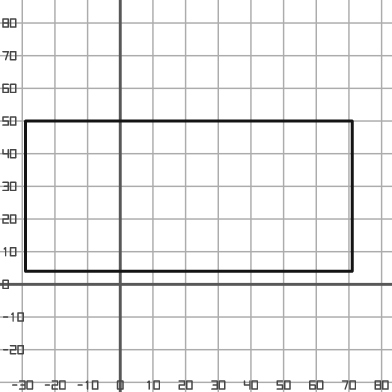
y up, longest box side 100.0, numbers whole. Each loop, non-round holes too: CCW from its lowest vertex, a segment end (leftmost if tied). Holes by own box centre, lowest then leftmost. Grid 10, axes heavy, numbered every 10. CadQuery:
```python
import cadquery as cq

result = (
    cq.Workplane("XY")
    .moveTo(-29.0, 4.0)
    .lineTo(71.0, 4.0)
    .lineTo(71.0, 50.0)
    .lineTo(-29.0, 50.0)
    .close()
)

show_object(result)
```